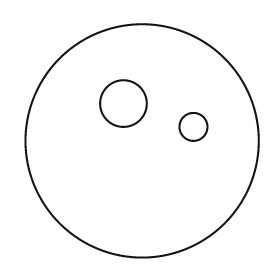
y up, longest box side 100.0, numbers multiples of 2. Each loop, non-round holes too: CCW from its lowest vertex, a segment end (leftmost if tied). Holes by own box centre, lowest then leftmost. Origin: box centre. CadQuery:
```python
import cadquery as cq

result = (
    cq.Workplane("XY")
    .moveTo(0.0, 0.0)
    .circle(50.0)
    .moveTo(22.0, 6.0)
    .circle(6.0)
    .moveTo(-8.0, 16.0)
    .circle(10.0)
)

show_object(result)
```